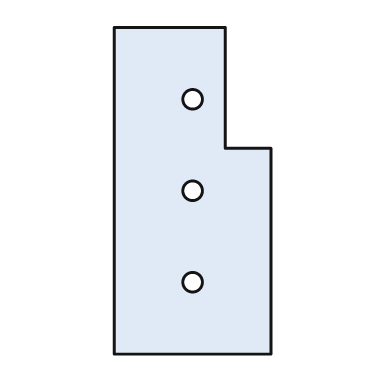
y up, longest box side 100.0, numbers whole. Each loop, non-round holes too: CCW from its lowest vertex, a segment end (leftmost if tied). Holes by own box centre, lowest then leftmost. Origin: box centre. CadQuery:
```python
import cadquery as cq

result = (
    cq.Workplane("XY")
    .moveTo(-24.0, -50.0)
    .lineTo(24.0, -50.0)
    .lineTo(24.0, 13.0)
    .lineTo(10.0, 13.0)
    .lineTo(10.0, 50.0)
    .lineTo(-24.0, 50.0)
    .close()
    .moveTo(0.0, -28.0)
    .circle(3.0)
    .moveTo(0.0, 0.0)
    .circle(3.0)
    .moveTo(0.0, 28.0)
    .circle(3.0)
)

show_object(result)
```